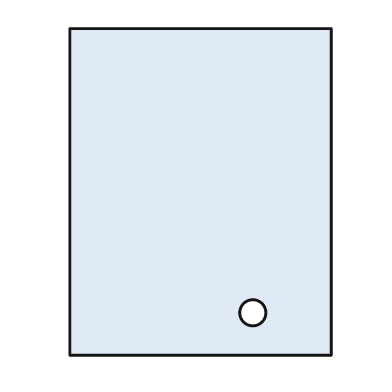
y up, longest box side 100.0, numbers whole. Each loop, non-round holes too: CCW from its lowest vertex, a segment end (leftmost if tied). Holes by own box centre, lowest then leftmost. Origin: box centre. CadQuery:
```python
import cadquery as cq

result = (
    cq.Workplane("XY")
    .moveTo(-40.0, -50.0)
    .lineTo(40.0, -50.0)
    .lineTo(40.0, 50.0)
    .lineTo(-40.0, 50.0)
    .close()
    .moveTo(16.0, -37.0)
    .circle(4.0)
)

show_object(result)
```